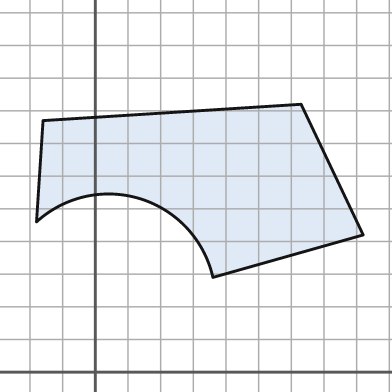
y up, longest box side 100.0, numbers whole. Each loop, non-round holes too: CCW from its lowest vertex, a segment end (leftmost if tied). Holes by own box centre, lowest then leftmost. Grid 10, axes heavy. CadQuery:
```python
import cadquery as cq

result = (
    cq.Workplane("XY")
    .moveTo(36.0, 29.0)
    .lineTo(82.0, 42.0)
    .lineTo(63.0, 82.0)
    .lineTo(-16.0, 77.0)
    .lineTo(-18.0, 46.0)
    .threePointArc((14.0, 53.0), (36.0, 29.0))
    .close()
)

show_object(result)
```